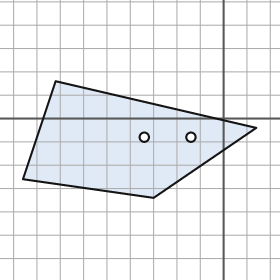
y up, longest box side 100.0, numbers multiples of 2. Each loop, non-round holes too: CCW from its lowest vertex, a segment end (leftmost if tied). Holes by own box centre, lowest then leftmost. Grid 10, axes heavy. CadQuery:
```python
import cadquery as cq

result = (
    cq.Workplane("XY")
    .moveTo(-30.0, -34.0)
    .lineTo(14.0, -4.0)
    .lineTo(-72.0, 16.0)
    .lineTo(-86.0, -26.0)
    .close()
    .moveTo(-34.0, -8.0)
    .circle(2.0)
    .moveTo(-14.0, -8.0)
    .circle(2.0)
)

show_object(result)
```